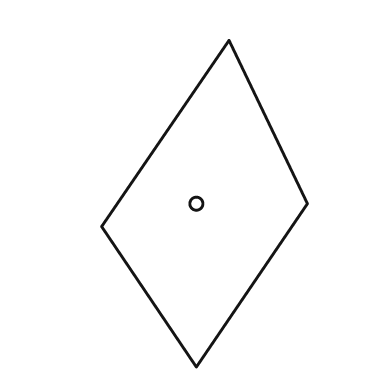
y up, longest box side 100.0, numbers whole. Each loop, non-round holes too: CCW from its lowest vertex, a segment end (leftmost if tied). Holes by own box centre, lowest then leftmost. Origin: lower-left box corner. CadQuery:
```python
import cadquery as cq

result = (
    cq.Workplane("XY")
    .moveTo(29.0, 0.0)
    .lineTo(63.0, 50.0)
    .lineTo(39.0, 100.0)
    .lineTo(0.0, 43.0)
    .close()
    .moveTo(29.0, 50.0)
    .circle(2.0)
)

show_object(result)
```